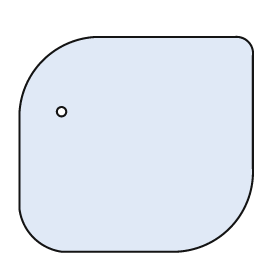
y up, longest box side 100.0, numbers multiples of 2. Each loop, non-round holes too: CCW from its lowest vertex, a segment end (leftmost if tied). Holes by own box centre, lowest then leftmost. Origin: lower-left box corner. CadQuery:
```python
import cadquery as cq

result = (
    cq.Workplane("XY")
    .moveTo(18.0, 0.0)
    .lineTo(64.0, 0.0)
    .threePointArc((90.0, 10.0), (100.0, 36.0))
    .lineTo(100.0, 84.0)
    .threePointArc((98.0, 90.0), (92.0, 92.0))
    .lineTo(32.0, 92.0)
    .threePointArc((10.0, 82.0), (0.0, 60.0))
    .lineTo(0.0, 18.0)
    .threePointArc((6.0, 6.0), (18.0, 0.0))
    .close()
    .moveTo(18.0, 60.0)
    .circle(2.0)
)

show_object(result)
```